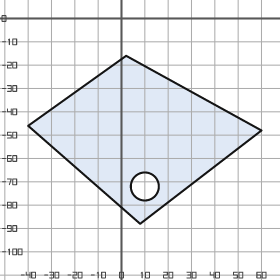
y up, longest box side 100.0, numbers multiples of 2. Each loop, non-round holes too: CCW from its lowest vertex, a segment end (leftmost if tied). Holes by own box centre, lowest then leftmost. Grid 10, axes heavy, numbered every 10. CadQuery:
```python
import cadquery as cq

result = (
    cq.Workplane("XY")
    .moveTo(8.0, -88.0)
    .lineTo(60.0, -48.0)
    .lineTo(2.0, -16.0)
    .lineTo(-40.0, -46.0)
    .close()
    .moveTo(10.0, -72.0)
    .circle(6.0)
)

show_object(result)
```